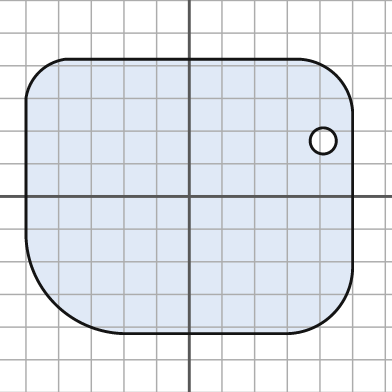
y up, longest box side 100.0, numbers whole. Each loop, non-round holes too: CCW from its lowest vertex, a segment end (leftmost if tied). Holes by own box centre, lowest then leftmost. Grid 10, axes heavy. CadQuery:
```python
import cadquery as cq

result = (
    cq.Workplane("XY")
    .moveTo(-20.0, -42.0)
    .lineTo(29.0, -42.0)
    .threePointArc((44.0, -36.0), (50.0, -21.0))
    .lineTo(50.0, 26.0)
    .threePointArc((45.0, 37.0), (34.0, 42.0))
    .lineTo(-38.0, 42.0)
    .threePointArc((-46.0, 38.0), (-50.0, 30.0))
    .lineTo(-50.0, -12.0)
    .threePointArc((-41.0, -33.0), (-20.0, -42.0))
    .close()
    .moveTo(41.0, 17.0)
    .circle(4.0)
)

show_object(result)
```